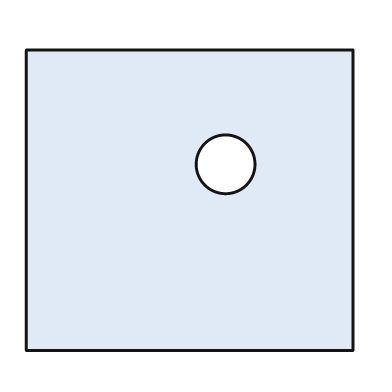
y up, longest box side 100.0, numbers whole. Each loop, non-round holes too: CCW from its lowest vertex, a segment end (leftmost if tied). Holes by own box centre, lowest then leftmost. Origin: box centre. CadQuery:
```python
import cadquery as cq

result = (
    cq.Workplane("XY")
    .moveTo(-50.0, -46.0)
    .lineTo(50.0, -46.0)
    .lineTo(50.0, 46.0)
    .lineTo(-50.0, 46.0)
    .close()
    .moveTo(11.0, 11.0)
    .circle(9.0)
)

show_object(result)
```